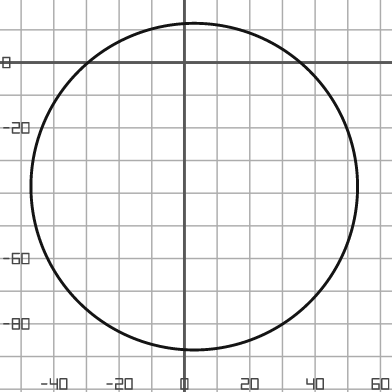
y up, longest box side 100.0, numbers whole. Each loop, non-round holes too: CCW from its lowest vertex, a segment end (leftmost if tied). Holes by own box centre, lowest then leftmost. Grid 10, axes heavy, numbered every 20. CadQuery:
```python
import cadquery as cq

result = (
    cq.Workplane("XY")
    .moveTo(3.0, -38.0)
    .circle(50.0)
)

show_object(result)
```